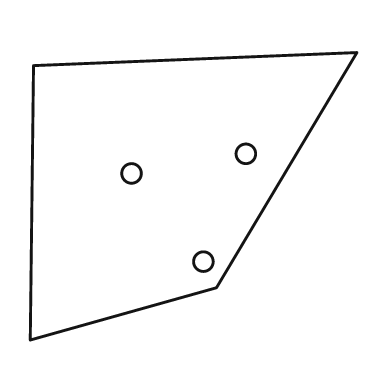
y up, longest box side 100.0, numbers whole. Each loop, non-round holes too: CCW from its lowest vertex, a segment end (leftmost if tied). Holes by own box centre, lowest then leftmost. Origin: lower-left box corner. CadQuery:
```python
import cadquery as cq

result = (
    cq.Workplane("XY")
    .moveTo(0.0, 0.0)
    .lineTo(57.0, 16.0)
    .lineTo(100.0, 88.0)
    .lineTo(1.0, 84.0)
    .close()
    .moveTo(53.0, 24.0)
    .circle(3.0)
    .moveTo(31.0, 51.0)
    .circle(3.0)
    .moveTo(66.0, 57.0)
    .circle(3.0)
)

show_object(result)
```